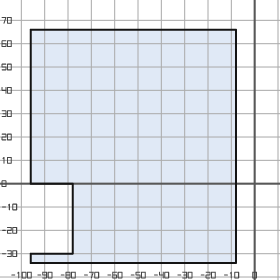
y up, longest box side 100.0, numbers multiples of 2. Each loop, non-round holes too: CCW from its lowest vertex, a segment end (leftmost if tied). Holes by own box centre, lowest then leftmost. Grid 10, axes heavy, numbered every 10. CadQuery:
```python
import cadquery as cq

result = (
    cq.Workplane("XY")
    .moveTo(-96.0, -34.0)
    .lineTo(-8.0, -34.0)
    .lineTo(-8.0, 66.0)
    .lineTo(-96.0, 66.0)
    .lineTo(-96.0, 0.0)
    .lineTo(-78.0, 0.0)
    .lineTo(-78.0, -30.0)
    .lineTo(-96.0, -30.0)
    .close()
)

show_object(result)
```